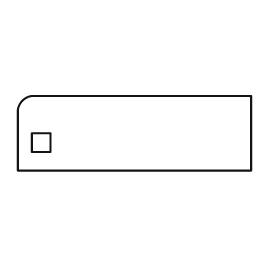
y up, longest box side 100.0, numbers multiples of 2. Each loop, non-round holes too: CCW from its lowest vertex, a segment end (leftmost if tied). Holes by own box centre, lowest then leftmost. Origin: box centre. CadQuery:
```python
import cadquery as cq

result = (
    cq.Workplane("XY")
    .moveTo(-50.0, -16.0)
    .lineTo(50.0, -16.0)
    .lineTo(50.0, 16.0)
    .lineTo(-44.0, 16.0)
    .threePointArc((-48.0, 14.0), (-50.0, 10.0))
    .close()
    .moveTo(-44.0, -8.0)
    .lineTo(-36.0, -8.0)
    .lineTo(-36.0, 0.0)
    .lineTo(-44.0, 0.0)
    .close()
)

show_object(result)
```